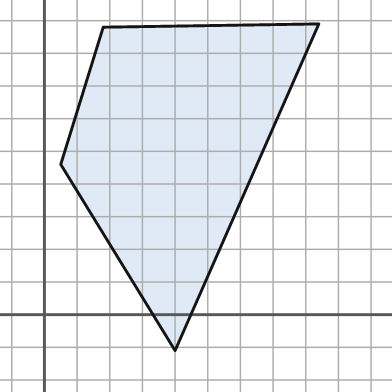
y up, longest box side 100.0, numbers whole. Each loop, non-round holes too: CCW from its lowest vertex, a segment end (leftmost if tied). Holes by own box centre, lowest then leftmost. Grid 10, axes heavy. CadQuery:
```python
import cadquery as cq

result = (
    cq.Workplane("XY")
    .moveTo(40.0, -11.0)
    .lineTo(84.0, 89.0)
    .lineTo(18.0, 88.0)
    .lineTo(5.0, 46.0)
    .close()
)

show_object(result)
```